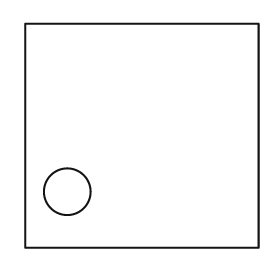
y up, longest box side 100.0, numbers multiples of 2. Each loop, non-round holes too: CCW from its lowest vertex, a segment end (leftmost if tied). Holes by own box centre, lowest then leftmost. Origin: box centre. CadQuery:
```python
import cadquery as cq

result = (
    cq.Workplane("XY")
    .moveTo(-50.0, -48.0)
    .lineTo(50.0, -48.0)
    .lineTo(50.0, 48.0)
    .lineTo(-50.0, 48.0)
    .close()
    .moveTo(-32.0, -24.0)
    .circle(10.0)
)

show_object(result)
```